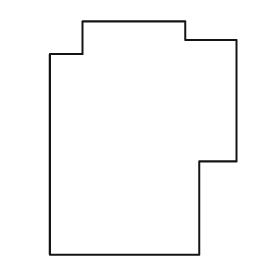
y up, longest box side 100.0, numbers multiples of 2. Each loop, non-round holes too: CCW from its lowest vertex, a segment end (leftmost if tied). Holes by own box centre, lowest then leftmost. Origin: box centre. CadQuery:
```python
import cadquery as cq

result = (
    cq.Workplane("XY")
    .moveTo(-40.0, -50.0)
    .lineTo(24.0, -50.0)
    .lineTo(24.0, -10.0)
    .lineTo(40.0, -10.0)
    .lineTo(40.0, 42.0)
    .lineTo(18.0, 42.0)
    .lineTo(18.0, 50.0)
    .lineTo(-26.0, 50.0)
    .lineTo(-26.0, 36.0)
    .lineTo(-40.0, 36.0)
    .close()
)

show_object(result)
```